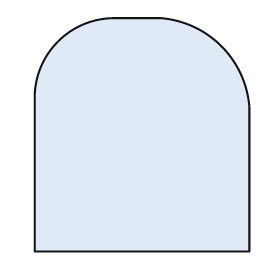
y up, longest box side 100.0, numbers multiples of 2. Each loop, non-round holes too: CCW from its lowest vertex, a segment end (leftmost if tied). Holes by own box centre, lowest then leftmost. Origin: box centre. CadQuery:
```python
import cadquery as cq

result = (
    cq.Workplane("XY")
    .moveTo(-46.0, -50.0)
    .lineTo(46.0, -50.0)
    .lineTo(46.0, 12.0)
    .threePointArc((34.0, 38.0), (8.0, 50.0))
    .lineTo(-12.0, 50.0)
    .threePointArc((-36.0, 40.0), (-46.0, 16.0))
    .close()
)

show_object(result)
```